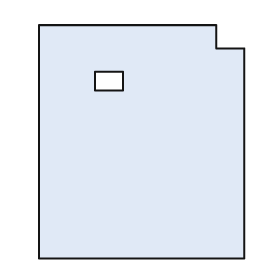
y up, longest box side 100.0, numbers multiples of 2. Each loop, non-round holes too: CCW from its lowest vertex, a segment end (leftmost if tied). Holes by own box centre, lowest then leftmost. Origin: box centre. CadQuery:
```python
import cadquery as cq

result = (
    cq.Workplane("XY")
    .moveTo(-44.0, -50.0)
    .lineTo(44.0, -50.0)
    .lineTo(44.0, 40.0)
    .lineTo(32.0, 40.0)
    .lineTo(32.0, 50.0)
    .lineTo(-44.0, 50.0)
    .close()
    .moveTo(-20.0, 22.0)
    .lineTo(-8.0, 22.0)
    .lineTo(-8.0, 30.0)
    .lineTo(-20.0, 30.0)
    .close()
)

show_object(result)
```